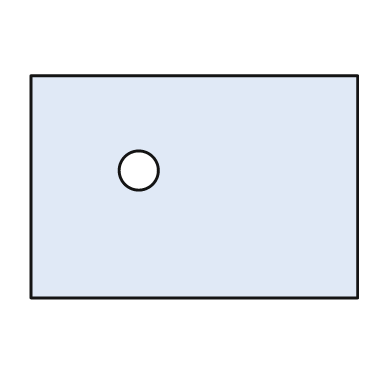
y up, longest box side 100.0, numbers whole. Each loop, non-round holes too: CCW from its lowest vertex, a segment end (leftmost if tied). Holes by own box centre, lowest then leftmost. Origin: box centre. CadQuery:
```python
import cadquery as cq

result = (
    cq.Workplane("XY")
    .moveTo(-50.0, -34.0)
    .lineTo(50.0, -34.0)
    .lineTo(50.0, 34.0)
    .lineTo(-50.0, 34.0)
    .close()
    .moveTo(-17.0, 5.0)
    .circle(6.0)
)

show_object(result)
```